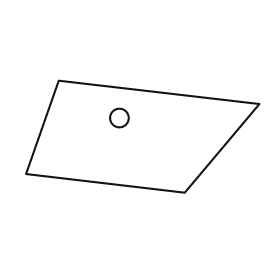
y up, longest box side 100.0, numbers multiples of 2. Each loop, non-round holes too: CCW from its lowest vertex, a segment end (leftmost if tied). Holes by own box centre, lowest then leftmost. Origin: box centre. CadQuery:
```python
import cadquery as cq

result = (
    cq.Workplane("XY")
    .moveTo(18.0, -24.0)
    .lineTo(50.0, 14.0)
    .lineTo(-36.0, 24.0)
    .lineTo(-50.0, -16.0)
    .close()
    .moveTo(-10.0, 8.0)
    .circle(4.0)
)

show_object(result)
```